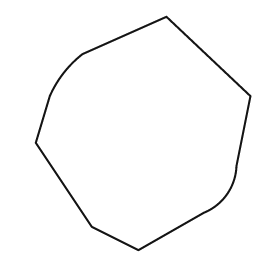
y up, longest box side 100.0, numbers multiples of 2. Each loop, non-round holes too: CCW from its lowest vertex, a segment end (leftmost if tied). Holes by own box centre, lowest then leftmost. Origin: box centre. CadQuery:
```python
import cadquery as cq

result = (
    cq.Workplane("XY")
    .moveTo(-2.0, -50.0)
    .lineTo(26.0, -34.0)
    .threePointArc((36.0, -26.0), (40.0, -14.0))
    .lineTo(46.0, 16.0)
    .lineTo(10.0, 50.0)
    .lineTo(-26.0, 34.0)
    .threePointArc((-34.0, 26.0), (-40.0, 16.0))
    .lineTo(-46.0, -4.0)
    .lineTo(-22.0, -40.0)
    .close()
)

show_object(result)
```